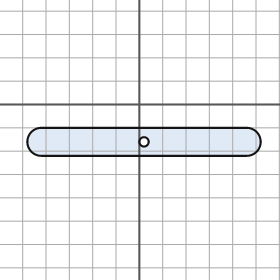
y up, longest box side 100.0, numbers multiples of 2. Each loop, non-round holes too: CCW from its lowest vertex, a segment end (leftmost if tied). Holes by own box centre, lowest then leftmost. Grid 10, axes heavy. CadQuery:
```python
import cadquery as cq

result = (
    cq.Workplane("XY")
    .moveTo(-42.0, -22.0)
    .lineTo(46.0, -22.0)
    .threePointArc((52.0, -16.0), (46.0, -10.0))
    .lineTo(-42.0, -10.0)
    .threePointArc((-48.0, -16.0), (-42.0, -22.0))
    .close()
    .moveTo(2.0, -16.0)
    .circle(2.0)
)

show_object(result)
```